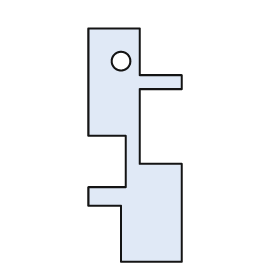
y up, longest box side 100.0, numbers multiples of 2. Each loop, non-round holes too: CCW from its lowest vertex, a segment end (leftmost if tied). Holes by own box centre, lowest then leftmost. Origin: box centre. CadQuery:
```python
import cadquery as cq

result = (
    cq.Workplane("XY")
    .moveTo(-6.0, -50.0)
    .lineTo(20.0, -50.0)
    .lineTo(20.0, -8.0)
    .lineTo(2.0, -8.0)
    .lineTo(2.0, 24.0)
    .lineTo(20.0, 24.0)
    .lineTo(20.0, 30.0)
    .lineTo(2.0, 30.0)
    .lineTo(2.0, 50.0)
    .lineTo(-20.0, 50.0)
    .lineTo(-20.0, 4.0)
    .lineTo(-4.0, 4.0)
    .lineTo(-4.0, -18.0)
    .lineTo(-20.0, -18.0)
    .lineTo(-20.0, -26.0)
    .lineTo(-6.0, -26.0)
    .close()
    .moveTo(-6.0, 36.0)
    .circle(4.0)
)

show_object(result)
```